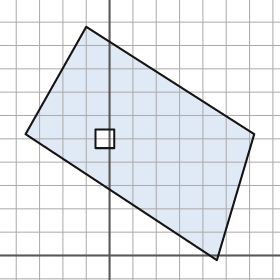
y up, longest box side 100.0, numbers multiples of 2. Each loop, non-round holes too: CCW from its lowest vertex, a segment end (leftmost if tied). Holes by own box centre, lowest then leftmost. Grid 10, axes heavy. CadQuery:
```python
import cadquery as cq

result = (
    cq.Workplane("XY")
    .moveTo(46.0, -2.0)
    .lineTo(62.0, 52.0)
    .lineTo(-10.0, 98.0)
    .lineTo(-36.0, 52.0)
    .close()
    .moveTo(-6.0, 46.0)
    .lineTo(2.0, 46.0)
    .lineTo(2.0, 54.0)
    .lineTo(-6.0, 54.0)
    .close()
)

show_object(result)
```